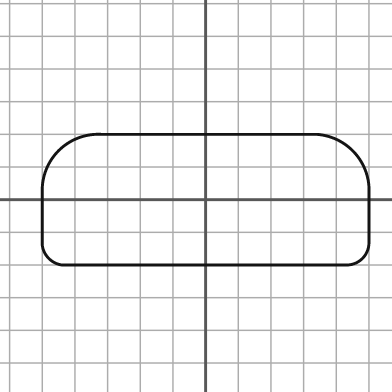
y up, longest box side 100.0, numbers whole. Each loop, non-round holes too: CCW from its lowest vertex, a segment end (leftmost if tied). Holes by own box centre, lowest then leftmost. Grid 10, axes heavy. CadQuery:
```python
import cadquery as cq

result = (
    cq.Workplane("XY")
    .moveTo(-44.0, -20.0)
    .lineTo(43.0, -20.0)
    .threePointArc((48.0, -18.0), (50.0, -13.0))
    .lineTo(50.0, 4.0)
    .threePointArc((45.0, 15.0), (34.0, 20.0))
    .lineTo(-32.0, 20.0)
    .threePointArc((-45.0, 15.0), (-50.0, 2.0))
    .lineTo(-50.0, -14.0)
    .threePointArc((-48.0, -18.0), (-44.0, -20.0))
    .close()
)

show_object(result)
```